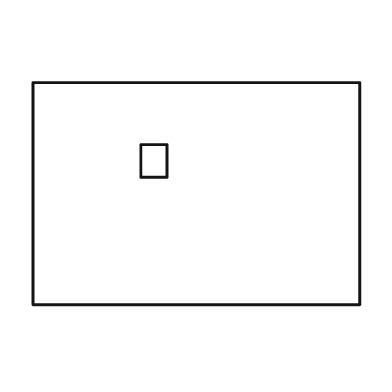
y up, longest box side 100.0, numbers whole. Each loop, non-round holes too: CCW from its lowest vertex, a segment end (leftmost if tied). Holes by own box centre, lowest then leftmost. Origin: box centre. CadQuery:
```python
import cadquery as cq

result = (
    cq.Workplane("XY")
    .moveTo(-50.0, -34.0)
    .lineTo(50.0, -34.0)
    .lineTo(50.0, 34.0)
    .lineTo(-50.0, 34.0)
    .close()
    .moveTo(-17.0, 5.0)
    .lineTo(-9.0, 5.0)
    .lineTo(-9.0, 15.0)
    .lineTo(-17.0, 15.0)
    .close()
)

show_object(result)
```